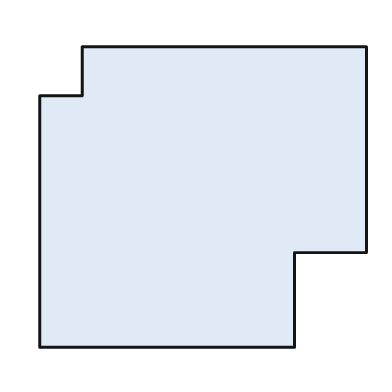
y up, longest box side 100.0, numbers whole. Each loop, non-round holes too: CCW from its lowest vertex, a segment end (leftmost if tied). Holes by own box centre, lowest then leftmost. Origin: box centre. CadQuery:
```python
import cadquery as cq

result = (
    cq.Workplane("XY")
    .moveTo(-50.0, -46.0)
    .lineTo(28.0, -46.0)
    .lineTo(28.0, -17.0)
    .lineTo(50.0, -17.0)
    .lineTo(50.0, 46.0)
    .lineTo(-37.0, 46.0)
    .lineTo(-37.0, 31.0)
    .lineTo(-50.0, 31.0)
    .close()
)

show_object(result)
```